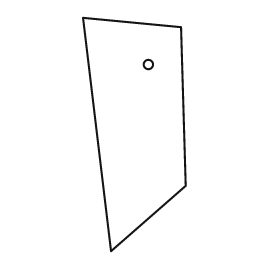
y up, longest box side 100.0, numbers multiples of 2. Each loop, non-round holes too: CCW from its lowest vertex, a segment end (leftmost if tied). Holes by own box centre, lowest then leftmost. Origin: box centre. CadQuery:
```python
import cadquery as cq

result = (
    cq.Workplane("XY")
    .moveTo(-10.0, -50.0)
    .lineTo(22.0, -22.0)
    .lineTo(20.0, 46.0)
    .lineTo(-22.0, 50.0)
    .close()
    .moveTo(6.0, 30.0)
    .circle(2.0)
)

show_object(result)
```